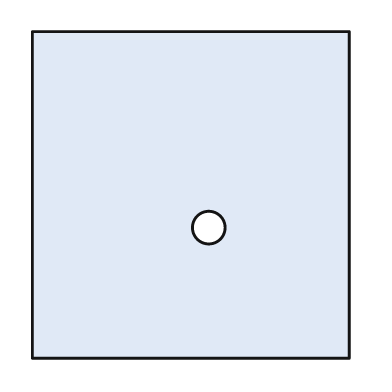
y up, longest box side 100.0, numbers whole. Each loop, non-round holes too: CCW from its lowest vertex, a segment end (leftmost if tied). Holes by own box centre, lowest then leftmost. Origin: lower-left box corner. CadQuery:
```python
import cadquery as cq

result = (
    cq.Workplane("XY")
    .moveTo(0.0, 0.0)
    .lineTo(97.0, 0.0)
    .lineTo(97.0, 100.0)
    .lineTo(0.0, 100.0)
    .close()
    .moveTo(54.0, 40.0)
    .circle(5.0)
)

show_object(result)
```